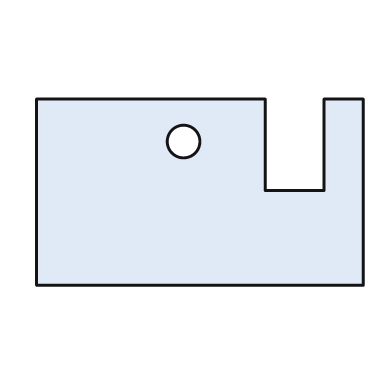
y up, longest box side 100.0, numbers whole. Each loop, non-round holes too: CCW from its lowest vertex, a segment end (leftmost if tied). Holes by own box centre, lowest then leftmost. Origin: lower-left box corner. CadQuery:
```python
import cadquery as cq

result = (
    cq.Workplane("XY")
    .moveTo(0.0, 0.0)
    .lineTo(100.0, 0.0)
    .lineTo(100.0, 57.0)
    .lineTo(88.0, 57.0)
    .lineTo(88.0, 29.0)
    .lineTo(70.0, 29.0)
    .lineTo(70.0, 57.0)
    .lineTo(0.0, 57.0)
    .close()
    .moveTo(45.0, 44.0)
    .circle(5.0)
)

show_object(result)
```